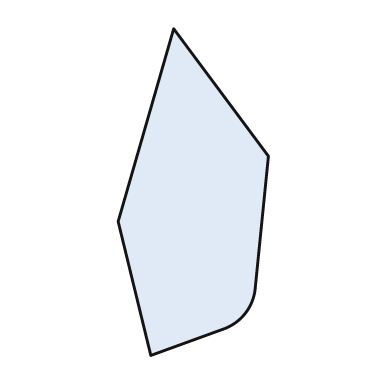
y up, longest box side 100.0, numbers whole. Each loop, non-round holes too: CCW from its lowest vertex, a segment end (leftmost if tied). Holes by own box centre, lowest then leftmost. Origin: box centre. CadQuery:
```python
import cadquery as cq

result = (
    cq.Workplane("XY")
    .moveTo(-13.0, -50.0)
    .lineTo(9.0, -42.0)
    .threePointArc((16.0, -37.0), (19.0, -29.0))
    .lineTo(23.0, 11.0)
    .lineTo(-6.0, 50.0)
    .lineTo(-23.0, -9.0)
    .close()
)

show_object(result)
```